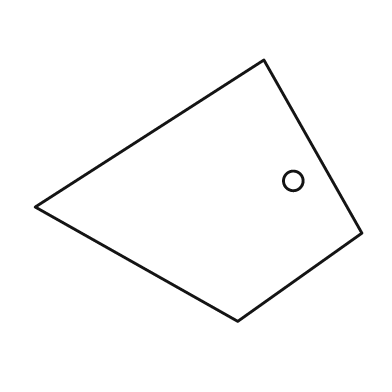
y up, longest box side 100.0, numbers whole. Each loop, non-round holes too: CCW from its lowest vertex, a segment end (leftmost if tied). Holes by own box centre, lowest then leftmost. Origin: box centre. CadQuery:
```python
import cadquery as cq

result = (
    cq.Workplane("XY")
    .moveTo(12.0, -40.0)
    .lineTo(50.0, -13.0)
    .lineTo(20.0, 40.0)
    .lineTo(-50.0, -5.0)
    .close()
    .moveTo(29.0, 3.0)
    .circle(3.0)
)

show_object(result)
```